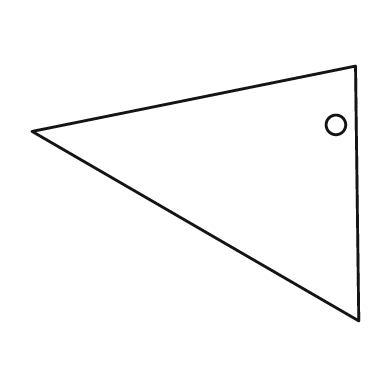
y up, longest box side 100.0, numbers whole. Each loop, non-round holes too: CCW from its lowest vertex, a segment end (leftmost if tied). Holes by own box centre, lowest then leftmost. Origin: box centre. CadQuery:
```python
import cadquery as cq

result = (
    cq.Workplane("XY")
    .moveTo(50.0, -39.0)
    .lineTo(49.0, 39.0)
    .lineTo(-50.0, 19.0)
    .close()
    .moveTo(43.0, 21.0)
    .circle(3.0)
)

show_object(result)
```